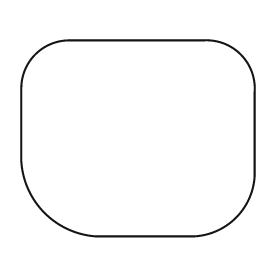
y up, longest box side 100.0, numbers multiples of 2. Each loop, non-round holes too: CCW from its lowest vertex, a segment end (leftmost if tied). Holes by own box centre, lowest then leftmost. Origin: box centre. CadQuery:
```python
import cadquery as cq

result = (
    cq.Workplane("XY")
    .moveTo(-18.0, -42.0)
    .lineTo(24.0, -42.0)
    .threePointArc((42.0, -34.0), (50.0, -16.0))
    .lineTo(50.0, 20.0)
    .threePointArc((44.0, 36.0), (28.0, 42.0))
    .lineTo(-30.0, 42.0)
    .threePointArc((-44.0, 36.0), (-50.0, 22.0))
    .lineTo(-50.0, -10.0)
    .threePointArc((-40.0, -32.0), (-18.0, -42.0))
    .close()
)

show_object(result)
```